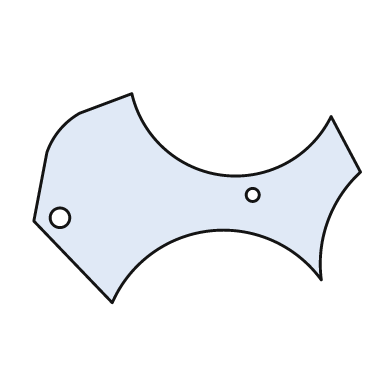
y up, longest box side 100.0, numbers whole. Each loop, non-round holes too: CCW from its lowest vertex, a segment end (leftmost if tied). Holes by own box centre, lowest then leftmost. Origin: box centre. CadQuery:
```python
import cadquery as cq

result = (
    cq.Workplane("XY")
    .moveTo(-26.0, -32.0)
    .threePointArc((4.0, -10.0), (38.0, -25.0))
    .threePointArc((40.0, -7.0), (50.0, 8.0))
    .lineTo(41.0, 25.0)
    .threePointArc((8.0, 7.0), (-20.0, 32.0))
    .lineTo(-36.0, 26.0)
    .threePointArc((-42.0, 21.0), (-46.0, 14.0))
    .lineTo(-50.0, -7.0)
    .close()
    .moveTo(-42.0, -6.0)
    .circle(3.0)
    .moveTo(17.0, 1.0)
    .circle(2.0)
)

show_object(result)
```